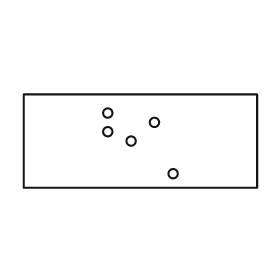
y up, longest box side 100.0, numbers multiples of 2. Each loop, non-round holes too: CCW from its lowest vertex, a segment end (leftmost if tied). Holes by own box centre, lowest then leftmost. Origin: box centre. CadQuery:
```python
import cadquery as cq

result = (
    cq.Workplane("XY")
    .moveTo(-50.0, -20.0)
    .lineTo(50.0, -20.0)
    .lineTo(50.0, 20.0)
    .lineTo(-50.0, 20.0)
    .close()
    .moveTo(14.0, -14.0)
    .circle(2.0)
    .moveTo(-4.0, 0.0)
    .circle(2.0)
    .moveTo(-14.0, 4.0)
    .circle(2.0)
    .moveTo(6.0, 8.0)
    .circle(2.0)
    .moveTo(-14.0, 12.0)
    .circle(2.0)
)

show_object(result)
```